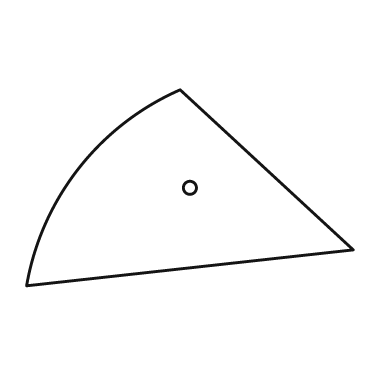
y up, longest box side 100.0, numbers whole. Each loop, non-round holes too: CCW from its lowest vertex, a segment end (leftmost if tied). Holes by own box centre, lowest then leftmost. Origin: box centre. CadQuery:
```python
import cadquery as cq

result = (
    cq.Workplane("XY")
    .moveTo(-50.0, -30.0)
    .lineTo(50.0, -19.0)
    .lineTo(-3.0, 30.0)
    .threePointArc((-34.0, 6.0), (-50.0, -30.0))
    .close()
    .moveTo(0.0, 0.0)
    .circle(2.0)
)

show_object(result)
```